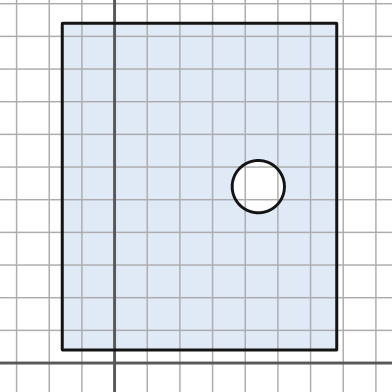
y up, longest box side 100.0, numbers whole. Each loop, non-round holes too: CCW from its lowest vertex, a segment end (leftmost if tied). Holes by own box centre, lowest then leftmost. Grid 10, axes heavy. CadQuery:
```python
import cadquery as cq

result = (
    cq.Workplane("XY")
    .moveTo(-16.0, 4.0)
    .lineTo(68.0, 4.0)
    .lineTo(68.0, 104.0)
    .lineTo(-16.0, 104.0)
    .close()
    .moveTo(44.0, 54.0)
    .circle(8.0)
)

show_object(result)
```